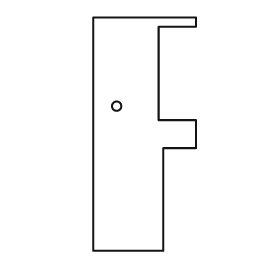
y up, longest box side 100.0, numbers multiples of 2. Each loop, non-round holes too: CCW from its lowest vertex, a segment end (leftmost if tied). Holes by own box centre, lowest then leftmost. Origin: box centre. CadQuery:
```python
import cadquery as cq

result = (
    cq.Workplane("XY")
    .moveTo(-22.0, -50.0)
    .lineTo(8.0, -50.0)
    .lineTo(8.0, -6.0)
    .lineTo(22.0, -6.0)
    .lineTo(22.0, 6.0)
    .lineTo(6.0, 6.0)
    .lineTo(6.0, 46.0)
    .lineTo(22.0, 46.0)
    .lineTo(22.0, 50.0)
    .lineTo(-22.0, 50.0)
    .close()
    .moveTo(-12.0, 12.0)
    .circle(2.0)
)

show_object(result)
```